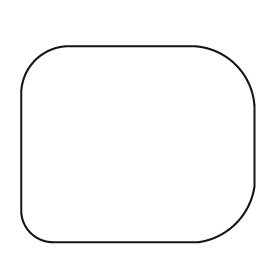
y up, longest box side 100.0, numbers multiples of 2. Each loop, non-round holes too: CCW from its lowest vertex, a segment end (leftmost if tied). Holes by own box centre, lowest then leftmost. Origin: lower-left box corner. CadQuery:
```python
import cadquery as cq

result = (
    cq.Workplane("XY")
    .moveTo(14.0, 0.0)
    .lineTo(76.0, 0.0)
    .threePointArc((92.0, 8.0), (100.0, 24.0))
    .lineTo(100.0, 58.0)
    .threePointArc((92.0, 76.0), (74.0, 84.0))
    .lineTo(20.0, 84.0)
    .threePointArc((6.0, 78.0), (0.0, 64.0))
    .lineTo(0.0, 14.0)
    .threePointArc((4.0, 4.0), (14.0, 0.0))
    .close()
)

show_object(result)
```